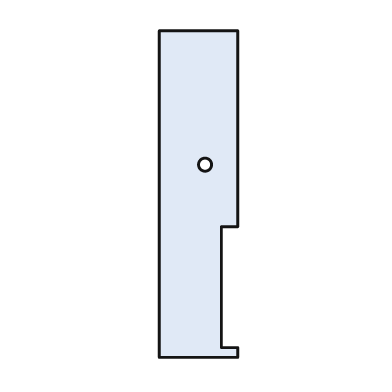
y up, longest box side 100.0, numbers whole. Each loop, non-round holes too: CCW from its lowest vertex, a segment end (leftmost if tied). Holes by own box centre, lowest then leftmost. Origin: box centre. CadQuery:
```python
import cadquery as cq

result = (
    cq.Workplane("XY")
    .moveTo(-12.0, -50.0)
    .lineTo(12.0, -50.0)
    .lineTo(12.0, -47.0)
    .lineTo(7.0, -47.0)
    .lineTo(7.0, -10.0)
    .lineTo(12.0, -10.0)
    .lineTo(12.0, 50.0)
    .lineTo(-12.0, 50.0)
    .close()
    .moveTo(2.0, 9.0)
    .circle(2.0)
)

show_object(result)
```